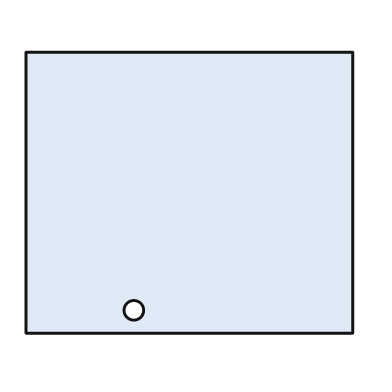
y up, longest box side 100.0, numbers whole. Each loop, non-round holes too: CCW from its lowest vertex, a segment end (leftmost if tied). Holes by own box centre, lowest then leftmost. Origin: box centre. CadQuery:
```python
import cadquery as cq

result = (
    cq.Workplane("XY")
    .moveTo(-50.0, -43.0)
    .lineTo(50.0, -43.0)
    .lineTo(50.0, 43.0)
    .lineTo(-50.0, 43.0)
    .close()
    .moveTo(-17.0, -36.0)
    .circle(3.0)
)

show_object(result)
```